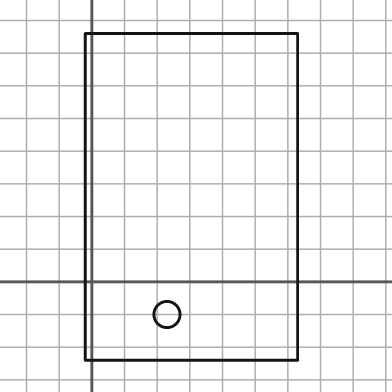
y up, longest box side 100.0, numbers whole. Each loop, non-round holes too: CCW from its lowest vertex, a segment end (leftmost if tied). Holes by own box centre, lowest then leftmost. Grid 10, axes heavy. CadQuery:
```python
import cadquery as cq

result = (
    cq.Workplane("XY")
    .moveTo(-2.0, -24.0)
    .lineTo(63.0, -24.0)
    .lineTo(63.0, 76.0)
    .lineTo(-2.0, 76.0)
    .close()
    .moveTo(23.0, -10.0)
    .circle(4.0)
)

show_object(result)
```